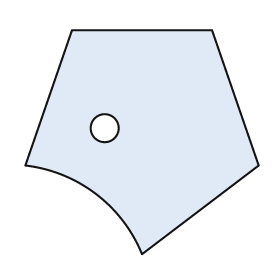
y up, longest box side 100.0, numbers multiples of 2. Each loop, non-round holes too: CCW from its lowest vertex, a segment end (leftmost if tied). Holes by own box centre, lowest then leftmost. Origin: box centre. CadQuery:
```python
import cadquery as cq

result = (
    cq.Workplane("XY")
    .moveTo(0.0, -48.0)
    .lineTo(50.0, -10.0)
    .lineTo(30.0, 48.0)
    .lineTo(-30.0, 48.0)
    .lineTo(-50.0, -10.0)
    .threePointArc((-20.0, -22.0), (0.0, -48.0))
    .close()
    .moveTo(-16.0, 6.0)
    .circle(6.0)
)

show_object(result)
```